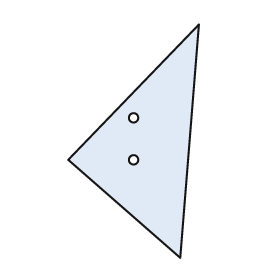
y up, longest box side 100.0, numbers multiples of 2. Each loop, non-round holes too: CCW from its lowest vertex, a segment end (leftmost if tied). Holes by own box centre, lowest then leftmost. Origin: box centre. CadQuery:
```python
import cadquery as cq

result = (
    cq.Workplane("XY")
    .moveTo(20.0, -50.0)
    .lineTo(28.0, 50.0)
    .lineTo(-28.0, -8.0)
    .close()
    .moveTo(0.0, -8.0)
    .circle(2.0)
    .moveTo(0.0, 10.0)
    .circle(2.0)
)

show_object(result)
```